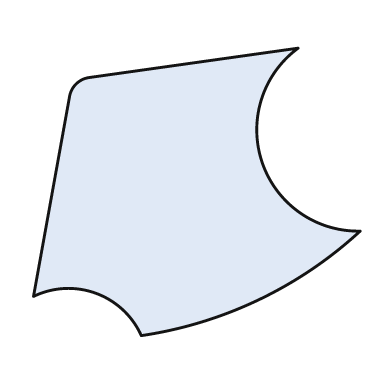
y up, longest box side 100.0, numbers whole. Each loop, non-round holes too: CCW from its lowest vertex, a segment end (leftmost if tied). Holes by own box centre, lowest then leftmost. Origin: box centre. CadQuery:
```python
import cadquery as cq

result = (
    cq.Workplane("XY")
    .moveTo(-17.0, -44.0)
    .threePointArc((19.0, -33.0), (50.0, -12.0))
    .threePointArc((20.0, 9.0), (31.0, 44.0))
    .lineTo(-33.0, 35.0)
    .threePointArc((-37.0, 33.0), (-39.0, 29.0))
    .lineTo(-50.0, -32.0)
    .threePointArc((-31.0, -31.0), (-17.0, -44.0))
    .close()
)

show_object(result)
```